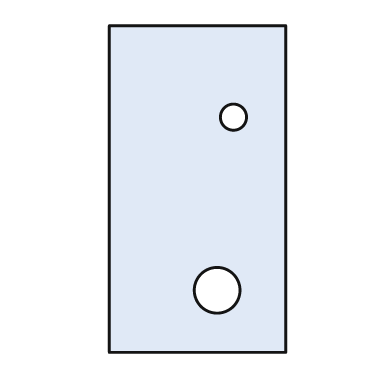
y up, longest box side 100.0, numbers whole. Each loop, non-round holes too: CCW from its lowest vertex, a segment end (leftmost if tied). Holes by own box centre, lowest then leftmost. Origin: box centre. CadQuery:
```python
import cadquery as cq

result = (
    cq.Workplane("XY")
    .moveTo(-27.0, -50.0)
    .lineTo(27.0, -50.0)
    .lineTo(27.0, 50.0)
    .lineTo(-27.0, 50.0)
    .close()
    .moveTo(6.0, -31.0)
    .circle(7.0)
    .moveTo(11.0, 22.0)
    .circle(4.0)
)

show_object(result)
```